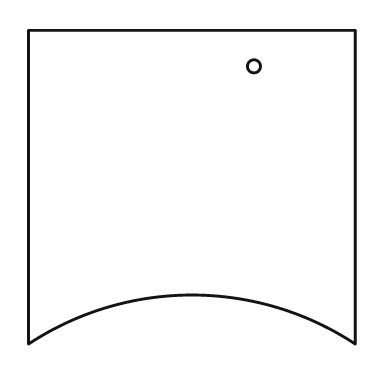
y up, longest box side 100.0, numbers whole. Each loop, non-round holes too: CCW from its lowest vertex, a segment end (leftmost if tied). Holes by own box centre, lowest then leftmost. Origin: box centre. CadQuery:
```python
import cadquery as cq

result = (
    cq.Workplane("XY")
    .moveTo(-50.0, -48.0)
    .threePointArc((0.0, -33.0), (50.0, -48.0))
    .lineTo(50.0, 48.0)
    .lineTo(-50.0, 48.0)
    .close()
    .moveTo(19.0, 37.0)
    .circle(2.0)
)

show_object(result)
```